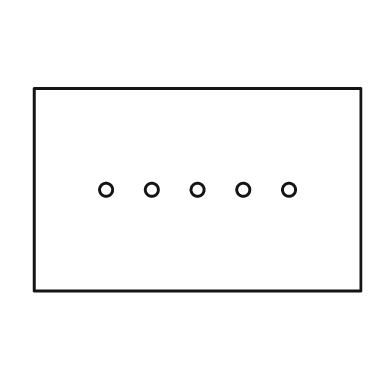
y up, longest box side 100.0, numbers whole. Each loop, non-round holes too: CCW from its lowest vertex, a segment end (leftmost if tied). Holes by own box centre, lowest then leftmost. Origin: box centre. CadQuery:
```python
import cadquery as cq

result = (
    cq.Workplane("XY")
    .moveTo(-50.0, -31.0)
    .lineTo(50.0, -31.0)
    .lineTo(50.0, 31.0)
    .lineTo(-50.0, 31.0)
    .close()
    .moveTo(-28.0, 0.0)
    .circle(2.0)
    .moveTo(-14.0, 0.0)
    .circle(2.0)
    .moveTo(0.0, 0.0)
    .circle(2.0)
    .moveTo(14.0, 0.0)
    .circle(2.0)
    .moveTo(28.0, 0.0)
    .circle(2.0)
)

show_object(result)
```